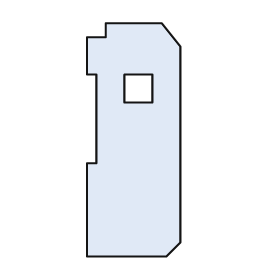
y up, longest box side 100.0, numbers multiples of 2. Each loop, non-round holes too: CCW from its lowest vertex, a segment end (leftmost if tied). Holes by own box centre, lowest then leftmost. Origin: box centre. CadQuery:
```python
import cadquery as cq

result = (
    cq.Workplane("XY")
    .moveTo(-20.0, -50.0)
    .lineTo(14.0, -50.0)
    .lineTo(20.0, -44.0)
    .lineTo(20.0, 40.0)
    .lineTo(12.0, 50.0)
    .lineTo(-12.0, 50.0)
    .lineTo(-12.0, 44.0)
    .lineTo(-20.0, 44.0)
    .lineTo(-20.0, 28.0)
    .lineTo(-16.0, 28.0)
    .lineTo(-16.0, -10.0)
    .lineTo(-20.0, -10.0)
    .close()
    .moveTo(-4.0, 16.0)
    .lineTo(8.0, 16.0)
    .lineTo(8.0, 28.0)
    .lineTo(-4.0, 28.0)
    .close()
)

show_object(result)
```